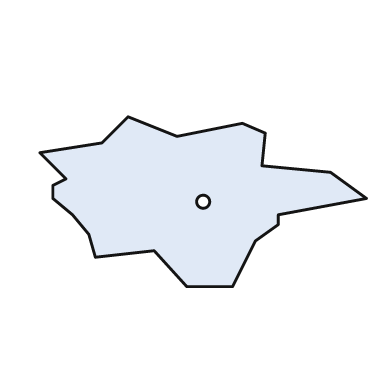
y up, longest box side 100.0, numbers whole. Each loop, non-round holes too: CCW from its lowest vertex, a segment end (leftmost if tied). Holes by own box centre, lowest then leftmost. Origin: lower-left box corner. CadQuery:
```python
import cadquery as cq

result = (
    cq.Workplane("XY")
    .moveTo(45.0, 0.0)
    .lineTo(59.0, 0.0)
    .lineTo(66.0, 14.0)
    .lineTo(73.0, 19.0)
    .lineTo(73.0, 22.0)
    .lineTo(100.0, 27.0)
    .lineTo(89.0, 35.0)
    .lineTo(68.0, 37.0)
    .lineTo(69.0, 47.0)
    .lineTo(62.0, 50.0)
    .lineTo(42.0, 46.0)
    .lineTo(27.0, 52.0)
    .lineTo(19.0, 44.0)
    .lineTo(0.0, 41.0)
    .lineTo(8.0, 33.0)
    .lineTo(4.0, 31.0)
    .lineTo(4.0, 27.0)
    .lineTo(10.0, 22.0)
    .lineTo(15.0, 16.0)
    .lineTo(17.0, 9.0)
    .lineTo(35.0, 11.0)
    .close()
    .moveTo(50.0, 26.0)
    .circle(2.0)
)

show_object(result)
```